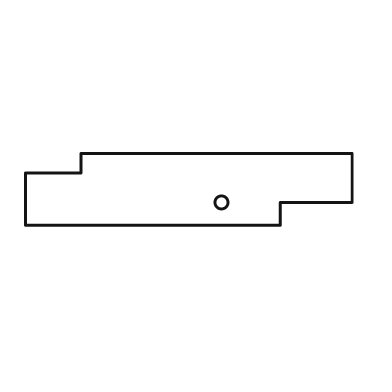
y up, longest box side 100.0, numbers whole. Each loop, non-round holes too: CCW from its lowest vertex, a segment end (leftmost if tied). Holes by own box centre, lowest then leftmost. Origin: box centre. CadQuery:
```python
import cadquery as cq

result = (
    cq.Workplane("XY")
    .moveTo(-50.0, -11.0)
    .lineTo(28.0, -11.0)
    .lineTo(28.0, -4.0)
    .lineTo(50.0, -4.0)
    .lineTo(50.0, 11.0)
    .lineTo(-33.0, 11.0)
    .lineTo(-33.0, 5.0)
    .lineTo(-50.0, 5.0)
    .close()
    .moveTo(10.0, -4.0)
    .circle(2.0)
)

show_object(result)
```